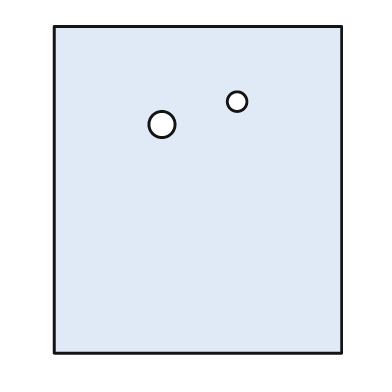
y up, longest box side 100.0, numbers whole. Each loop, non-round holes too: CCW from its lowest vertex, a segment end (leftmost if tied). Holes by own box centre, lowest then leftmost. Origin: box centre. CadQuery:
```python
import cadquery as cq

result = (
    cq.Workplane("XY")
    .moveTo(-44.0, -50.0)
    .lineTo(44.0, -50.0)
    .lineTo(44.0, 50.0)
    .lineTo(-44.0, 50.0)
    .close()
    .moveTo(-11.0, 20.0)
    .circle(4.0)
    .moveTo(12.0, 27.0)
    .circle(3.0)
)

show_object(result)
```